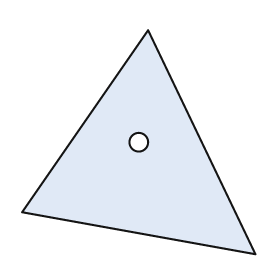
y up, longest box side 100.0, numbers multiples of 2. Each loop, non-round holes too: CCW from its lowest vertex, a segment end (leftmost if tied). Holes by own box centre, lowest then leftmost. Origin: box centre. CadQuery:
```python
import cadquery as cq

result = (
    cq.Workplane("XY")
    .moveTo(50.0, -48.0)
    .lineTo(4.0, 48.0)
    .lineTo(-50.0, -30.0)
    .close()
    .moveTo(0.0, 0.0)
    .circle(4.0)
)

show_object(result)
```